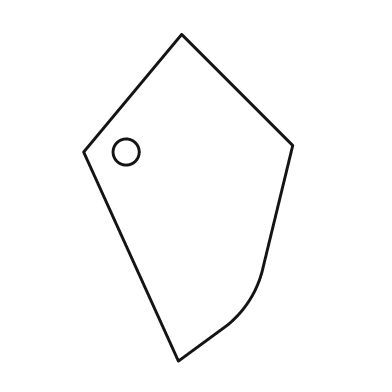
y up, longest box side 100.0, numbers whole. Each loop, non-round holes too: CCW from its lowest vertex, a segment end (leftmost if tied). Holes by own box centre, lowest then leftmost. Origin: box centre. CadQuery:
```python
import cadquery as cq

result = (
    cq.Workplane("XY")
    .moveTo(-3.0, -50.0)
    .lineTo(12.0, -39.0)
    .threePointArc((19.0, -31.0), (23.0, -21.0))
    .lineTo(32.0, 16.0)
    .lineTo(-2.0, 50.0)
    .lineTo(-32.0, 14.0)
    .close()
    .moveTo(-19.0, 14.0)
    .circle(4.0)
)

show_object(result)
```